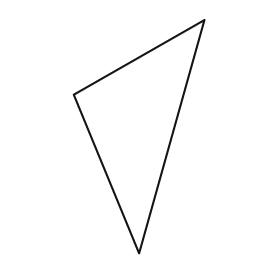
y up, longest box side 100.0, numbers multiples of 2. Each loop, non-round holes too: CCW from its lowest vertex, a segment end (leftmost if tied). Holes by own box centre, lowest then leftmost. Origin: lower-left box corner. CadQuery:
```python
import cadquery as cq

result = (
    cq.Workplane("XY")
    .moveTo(28.0, 0.0)
    .lineTo(56.0, 100.0)
    .lineTo(0.0, 68.0)
    .close()
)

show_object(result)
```